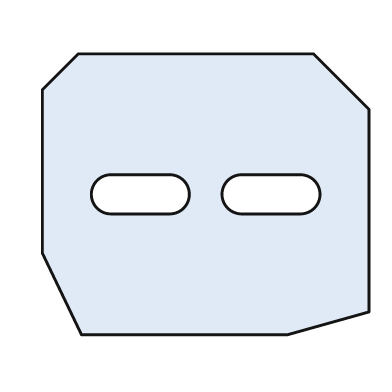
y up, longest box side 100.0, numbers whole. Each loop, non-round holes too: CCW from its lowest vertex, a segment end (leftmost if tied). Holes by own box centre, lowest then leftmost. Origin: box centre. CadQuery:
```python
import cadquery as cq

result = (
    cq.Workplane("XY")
    .moveTo(-38.0, -43.0)
    .lineTo(25.0, -43.0)
    .lineTo(50.0, -36.0)
    .lineTo(50.0, 26.0)
    .lineTo(33.0, 43.0)
    .lineTo(-39.0, 43.0)
    .lineTo(-50.0, 32.0)
    .lineTo(-50.0, -18.0)
    .close()
    .moveTo(-29.0, -6.0)
    .lineTo(-11.0, -6.0)
    .threePointArc((-5.0, 0.0), (-11.0, 6.0))
    .lineTo(-29.0, 6.0)
    .threePointArc((-35.0, 0.0), (-29.0, -6.0))
    .close()
    .moveTo(11.0, -6.0)
    .lineTo(29.0, -6.0)
    .threePointArc((35.0, 0.0), (29.0, 6.0))
    .lineTo(11.0, 6.0)
    .threePointArc((5.0, 0.0), (11.0, -6.0))
    .close()
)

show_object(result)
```